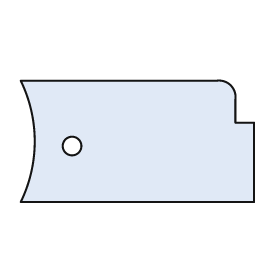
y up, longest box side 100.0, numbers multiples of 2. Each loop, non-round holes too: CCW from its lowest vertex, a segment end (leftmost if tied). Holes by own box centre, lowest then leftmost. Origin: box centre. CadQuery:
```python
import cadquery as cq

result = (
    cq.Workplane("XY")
    .moveTo(-50.0, -26.0)
    .lineTo(50.0, -26.0)
    .lineTo(50.0, 8.0)
    .lineTo(42.0, 8.0)
    .lineTo(42.0, 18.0)
    .threePointArc((40.0, 24.0), (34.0, 26.0))
    .lineTo(-50.0, 26.0)
    .threePointArc((-44.0, 0.0), (-50.0, -26.0))
    .close()
    .moveTo(-28.0, -2.0)
    .circle(4.0)
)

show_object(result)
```